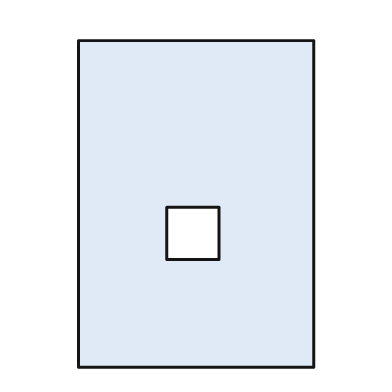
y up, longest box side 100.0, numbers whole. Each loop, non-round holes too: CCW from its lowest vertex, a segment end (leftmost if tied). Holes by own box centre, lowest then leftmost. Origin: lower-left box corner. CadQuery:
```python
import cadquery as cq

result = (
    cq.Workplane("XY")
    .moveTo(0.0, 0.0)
    .lineTo(72.0, 0.0)
    .lineTo(72.0, 100.0)
    .lineTo(0.0, 100.0)
    .close()
    .moveTo(27.0, 33.0)
    .lineTo(43.0, 33.0)
    .lineTo(43.0, 49.0)
    .lineTo(27.0, 49.0)
    .close()
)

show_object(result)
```